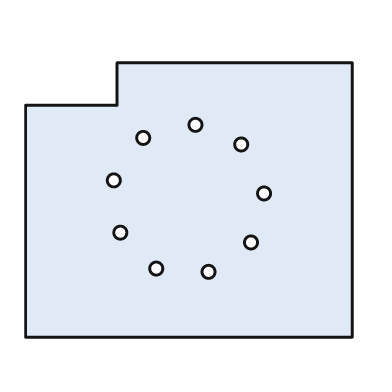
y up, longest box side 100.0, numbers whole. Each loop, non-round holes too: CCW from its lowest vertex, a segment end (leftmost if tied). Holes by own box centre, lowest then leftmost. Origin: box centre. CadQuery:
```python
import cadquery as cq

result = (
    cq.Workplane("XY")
    .moveTo(-50.0, -42.0)
    .lineTo(50.0, -42.0)
    .lineTo(50.0, 42.0)
    .lineTo(-22.0, 42.0)
    .lineTo(-22.0, 29.0)
    .lineTo(-50.0, 29.0)
    .close()
    .moveTo(6.0, -22.0)
    .circle(2.0)
    .moveTo(-10.0, -21.0)
    .circle(2.0)
    .moveTo(19.0, -13.0)
    .circle(2.0)
    .moveTo(-21.0, -10.0)
    .circle(2.0)
    .moveTo(23.0, 2.0)
    .circle(2.0)
    .moveTo(-23.0, 6.0)
    .circle(2.0)
    .moveTo(16.0, 17.0)
    .circle(2.0)
    .moveTo(-14.0, 19.0)
    .circle(2.0)
    .moveTo(2.0, 23.0)
    .circle(2.0)
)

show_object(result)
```